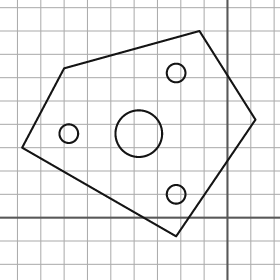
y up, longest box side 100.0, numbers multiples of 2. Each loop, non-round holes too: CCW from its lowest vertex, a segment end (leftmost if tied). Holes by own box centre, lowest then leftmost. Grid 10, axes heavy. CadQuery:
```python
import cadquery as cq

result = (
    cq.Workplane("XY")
    .moveTo(-22.0, -8.0)
    .lineTo(12.0, 42.0)
    .lineTo(-12.0, 80.0)
    .lineTo(-70.0, 64.0)
    .lineTo(-88.0, 30.0)
    .close()
    .moveTo(-22.0, 10.0)
    .circle(4.0)
    .moveTo(-68.0, 36.0)
    .circle(4.0)
    .moveTo(-38.0, 36.0)
    .circle(10.0)
    .moveTo(-22.0, 62.0)
    .circle(4.0)
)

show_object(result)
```